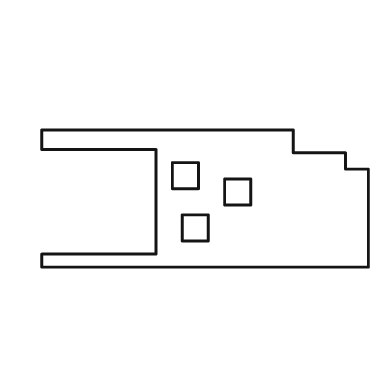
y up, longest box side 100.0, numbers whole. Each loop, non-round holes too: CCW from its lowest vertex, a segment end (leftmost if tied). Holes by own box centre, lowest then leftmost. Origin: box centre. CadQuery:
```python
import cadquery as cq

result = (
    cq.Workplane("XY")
    .moveTo(-50.0, -21.0)
    .lineTo(50.0, -21.0)
    .lineTo(50.0, 9.0)
    .lineTo(43.0, 9.0)
    .lineTo(43.0, 14.0)
    .lineTo(27.0, 14.0)
    .lineTo(27.0, 21.0)
    .lineTo(-50.0, 21.0)
    .lineTo(-50.0, 15.0)
    .lineTo(-15.0, 15.0)
    .lineTo(-15.0, -17.0)
    .lineTo(-50.0, -17.0)
    .close()
    .moveTo(-7.0, -13.0)
    .lineTo(1.0, -13.0)
    .lineTo(1.0, -5.0)
    .lineTo(-7.0, -5.0)
    .close()
    .moveTo(6.0, -2.0)
    .lineTo(14.0, -2.0)
    .lineTo(14.0, 6.0)
    .lineTo(6.0, 6.0)
    .close()
    .moveTo(-10.0, 3.0)
    .lineTo(-2.0, 3.0)
    .lineTo(-2.0, 11.0)
    .lineTo(-10.0, 11.0)
    .close()
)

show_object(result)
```